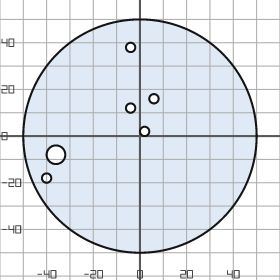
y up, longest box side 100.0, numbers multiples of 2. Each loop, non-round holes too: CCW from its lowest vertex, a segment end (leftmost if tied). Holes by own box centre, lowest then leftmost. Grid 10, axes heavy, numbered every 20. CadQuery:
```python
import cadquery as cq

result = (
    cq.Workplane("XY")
    .moveTo(0.0, 0.0)
    .circle(50.0)
    .moveTo(-40.0, -18.0)
    .circle(2.0)
    .moveTo(-36.0, -8.0)
    .circle(4.0)
    .moveTo(2.0, 2.0)
    .circle(2.0)
    .moveTo(-4.0, 12.0)
    .circle(2.0)
    .moveTo(6.0, 16.0)
    .circle(2.0)
    .moveTo(-4.0, 38.0)
    .circle(2.0)
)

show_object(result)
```